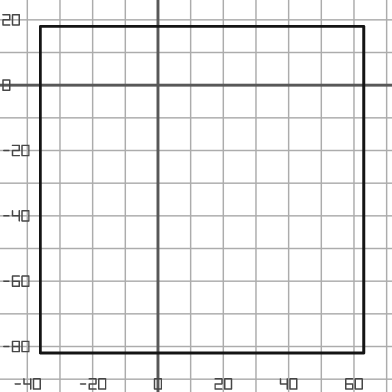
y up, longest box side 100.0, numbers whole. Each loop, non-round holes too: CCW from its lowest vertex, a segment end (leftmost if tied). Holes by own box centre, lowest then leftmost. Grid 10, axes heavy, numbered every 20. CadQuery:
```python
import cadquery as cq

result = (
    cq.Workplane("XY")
    .moveTo(-36.0, -82.0)
    .lineTo(63.0, -82.0)
    .lineTo(63.0, 18.0)
    .lineTo(-36.0, 18.0)
    .close()
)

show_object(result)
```